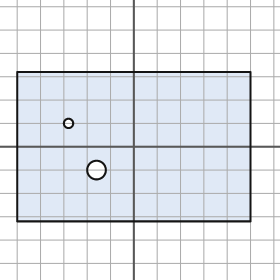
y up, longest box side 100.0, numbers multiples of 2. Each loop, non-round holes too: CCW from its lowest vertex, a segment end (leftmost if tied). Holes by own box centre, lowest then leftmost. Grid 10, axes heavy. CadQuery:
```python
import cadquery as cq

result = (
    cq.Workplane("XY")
    .moveTo(-50.0, -32.0)
    .lineTo(50.0, -32.0)
    .lineTo(50.0, 32.0)
    .lineTo(-50.0, 32.0)
    .close()
    .moveTo(-16.0, -10.0)
    .circle(4.0)
    .moveTo(-28.0, 10.0)
    .circle(2.0)
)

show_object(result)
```